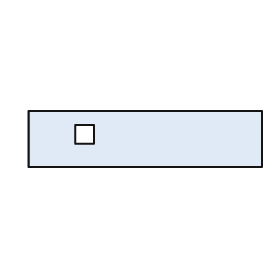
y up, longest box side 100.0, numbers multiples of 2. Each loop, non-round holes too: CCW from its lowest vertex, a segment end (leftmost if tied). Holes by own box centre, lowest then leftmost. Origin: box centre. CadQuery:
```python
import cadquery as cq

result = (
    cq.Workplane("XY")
    .moveTo(-50.0, -12.0)
    .lineTo(50.0, -12.0)
    .lineTo(50.0, 12.0)
    .lineTo(-50.0, 12.0)
    .close()
    .moveTo(-30.0, -2.0)
    .lineTo(-22.0, -2.0)
    .lineTo(-22.0, 6.0)
    .lineTo(-30.0, 6.0)
    .close()
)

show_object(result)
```